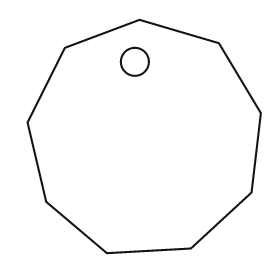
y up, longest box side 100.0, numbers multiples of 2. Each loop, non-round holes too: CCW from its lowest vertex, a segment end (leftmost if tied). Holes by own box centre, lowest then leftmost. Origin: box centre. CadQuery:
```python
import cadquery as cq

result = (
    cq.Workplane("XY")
    .moveTo(-16.0, -50.0)
    .lineTo(20.0, -48.0)
    .lineTo(46.0, -24.0)
    .lineTo(50.0, 10.0)
    .lineTo(32.0, 40.0)
    .lineTo(-2.0, 50.0)
    .lineTo(-34.0, 38.0)
    .lineTo(-50.0, 6.0)
    .lineTo(-42.0, -28.0)
    .close()
    .moveTo(-4.0, 32.0)
    .circle(6.0)
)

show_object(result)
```